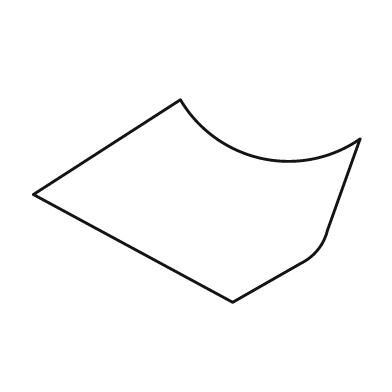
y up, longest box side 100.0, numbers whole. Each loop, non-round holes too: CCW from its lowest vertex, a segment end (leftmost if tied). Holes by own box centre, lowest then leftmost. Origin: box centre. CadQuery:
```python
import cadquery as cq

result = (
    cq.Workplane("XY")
    .moveTo(11.0, -31.0)
    .lineTo(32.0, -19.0)
    .threePointArc((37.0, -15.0), (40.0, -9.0))
    .lineTo(50.0, 19.0)
    .threePointArc((20.0, 13.0), (-5.0, 31.0))
    .lineTo(-50.0, 2.0)
    .close()
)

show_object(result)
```